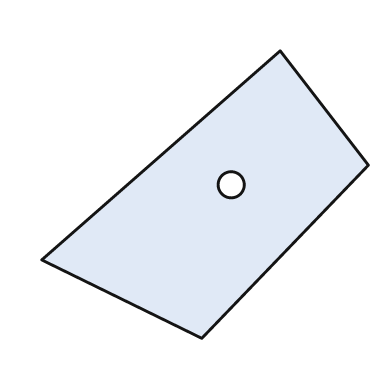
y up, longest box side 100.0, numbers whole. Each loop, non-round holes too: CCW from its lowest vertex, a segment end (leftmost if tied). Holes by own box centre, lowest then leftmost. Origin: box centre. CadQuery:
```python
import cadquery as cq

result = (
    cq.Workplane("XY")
    .moveTo(-1.0, -44.0)
    .lineTo(50.0, 9.0)
    .lineTo(23.0, 44.0)
    .lineTo(-50.0, -20.0)
    .close()
    .moveTo(8.0, 3.0)
    .circle(4.0)
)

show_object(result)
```